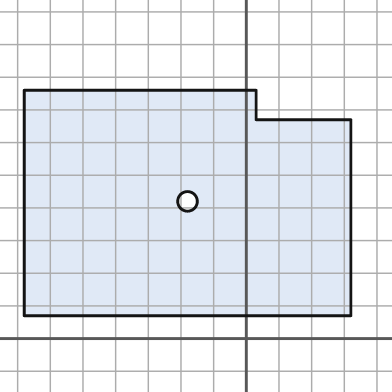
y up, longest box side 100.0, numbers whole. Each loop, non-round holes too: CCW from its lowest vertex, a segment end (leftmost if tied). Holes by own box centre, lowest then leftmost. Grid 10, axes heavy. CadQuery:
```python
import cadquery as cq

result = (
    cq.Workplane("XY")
    .moveTo(-68.0, 7.0)
    .lineTo(32.0, 7.0)
    .lineTo(32.0, 67.0)
    .lineTo(3.0, 67.0)
    .lineTo(3.0, 76.0)
    .lineTo(-68.0, 76.0)
    .close()
    .moveTo(-18.0, 42.0)
    .circle(3.0)
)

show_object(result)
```